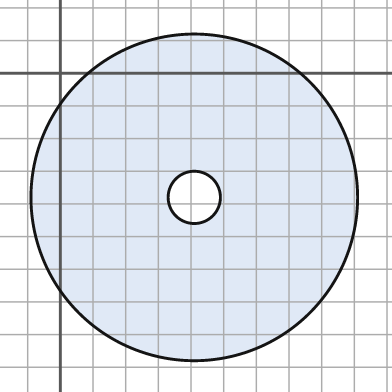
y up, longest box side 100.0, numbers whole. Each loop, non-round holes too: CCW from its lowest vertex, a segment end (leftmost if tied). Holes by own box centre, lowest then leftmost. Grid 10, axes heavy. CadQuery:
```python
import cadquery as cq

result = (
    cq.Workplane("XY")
    .moveTo(41.0, -38.0)
    .circle(50.0)
    .moveTo(41.0, -38.0)
    .circle(8.0)
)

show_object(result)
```